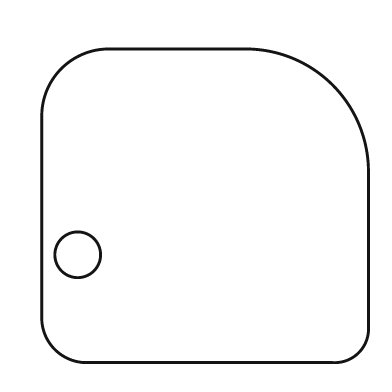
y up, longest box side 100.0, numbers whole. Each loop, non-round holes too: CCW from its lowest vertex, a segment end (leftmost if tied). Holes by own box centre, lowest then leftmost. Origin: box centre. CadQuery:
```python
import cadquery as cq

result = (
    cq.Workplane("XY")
    .moveTo(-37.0, -48.0)
    .lineTo(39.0, -48.0)
    .threePointArc((47.0, -45.0), (50.0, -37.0))
    .lineTo(50.0, 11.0)
    .threePointArc((39.0, 37.0), (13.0, 48.0))
    .lineTo(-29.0, 48.0)
    .threePointArc((-44.0, 42.0), (-50.0, 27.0))
    .lineTo(-50.0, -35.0)
    .threePointArc((-46.0, -44.0), (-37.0, -48.0))
    .close()
    .moveTo(-39.0, -15.0)
    .circle(7.0)
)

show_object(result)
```